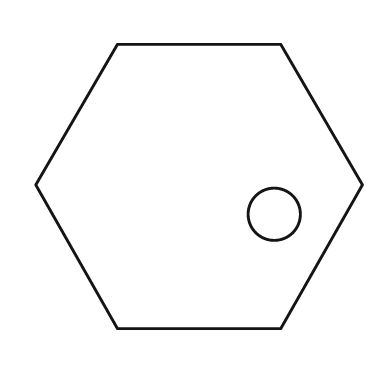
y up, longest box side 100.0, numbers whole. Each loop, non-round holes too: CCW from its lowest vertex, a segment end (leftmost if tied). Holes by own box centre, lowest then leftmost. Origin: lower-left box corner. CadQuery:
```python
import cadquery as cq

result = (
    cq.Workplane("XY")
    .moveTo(25.0, 0.0)
    .lineTo(75.0, 0.0)
    .lineTo(100.0, 44.0)
    .lineTo(75.0, 87.0)
    .lineTo(25.0, 87.0)
    .lineTo(0.0, 44.0)
    .close()
    .moveTo(73.0, 35.0)
    .circle(8.0)
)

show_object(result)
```